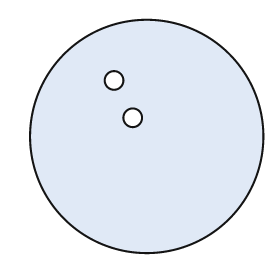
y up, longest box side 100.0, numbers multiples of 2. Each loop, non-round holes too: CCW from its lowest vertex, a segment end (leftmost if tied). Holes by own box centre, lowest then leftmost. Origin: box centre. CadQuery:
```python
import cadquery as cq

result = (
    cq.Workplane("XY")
    .moveTo(0.0, 0.0)
    .circle(50.0)
    .moveTo(-6.0, 8.0)
    .circle(4.0)
    .moveTo(-14.0, 24.0)
    .circle(4.0)
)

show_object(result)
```